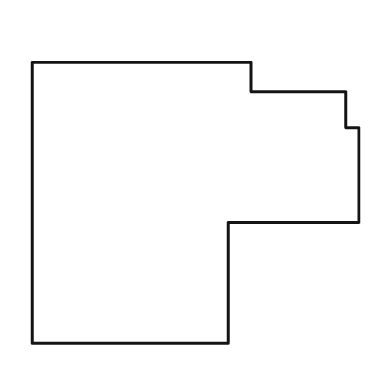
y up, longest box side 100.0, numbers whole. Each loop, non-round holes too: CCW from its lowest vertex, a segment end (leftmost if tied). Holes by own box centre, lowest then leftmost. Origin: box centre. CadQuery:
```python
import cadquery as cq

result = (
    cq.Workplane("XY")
    .moveTo(-50.0, -43.0)
    .lineTo(10.0, -43.0)
    .lineTo(10.0, -6.0)
    .lineTo(50.0, -6.0)
    .lineTo(50.0, 23.0)
    .lineTo(46.0, 23.0)
    .lineTo(46.0, 34.0)
    .lineTo(17.0, 34.0)
    .lineTo(17.0, 43.0)
    .lineTo(-50.0, 43.0)
    .close()
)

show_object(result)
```